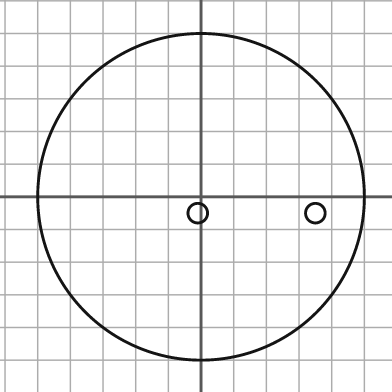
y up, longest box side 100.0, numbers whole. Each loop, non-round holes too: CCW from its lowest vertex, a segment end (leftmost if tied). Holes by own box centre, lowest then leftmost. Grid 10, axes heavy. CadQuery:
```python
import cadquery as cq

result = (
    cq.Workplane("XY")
    .moveTo(0.0, 0.0)
    .circle(50.0)
    .moveTo(-1.0, -5.0)
    .circle(3.0)
    .moveTo(35.0, -5.0)
    .circle(3.0)
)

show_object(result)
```